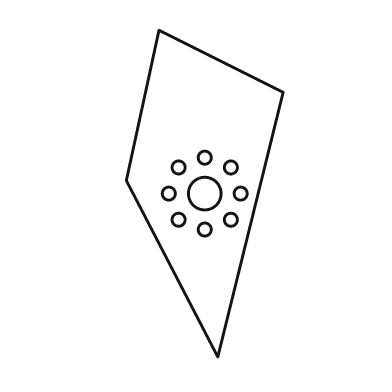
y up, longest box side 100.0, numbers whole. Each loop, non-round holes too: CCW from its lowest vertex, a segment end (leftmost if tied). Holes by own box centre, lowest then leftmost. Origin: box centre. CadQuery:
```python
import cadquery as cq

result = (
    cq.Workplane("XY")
    .moveTo(4.0, -50.0)
    .lineTo(24.0, 31.0)
    .lineTo(-14.0, 50.0)
    .lineTo(-24.0, 4.0)
    .close()
    .moveTo(0.0, -11.0)
    .circle(2.0)
    .moveTo(-8.0, -8.0)
    .circle(2.0)
    .moveTo(8.0, -8.0)
    .circle(2.0)
    .moveTo(-11.0, 0.0)
    .circle(2.0)
    .moveTo(0.0, 0.0)
    .circle(5.0)
    .moveTo(11.0, 0.0)
    .circle(2.0)
    .moveTo(-8.0, 8.0)
    .circle(2.0)
    .moveTo(8.0, 8.0)
    .circle(2.0)
    .moveTo(0.0, 11.0)
    .circle(2.0)
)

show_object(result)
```